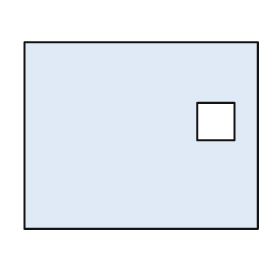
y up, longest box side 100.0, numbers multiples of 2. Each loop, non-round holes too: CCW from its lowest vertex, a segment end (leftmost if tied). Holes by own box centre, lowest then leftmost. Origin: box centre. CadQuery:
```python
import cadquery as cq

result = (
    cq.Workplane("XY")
    .moveTo(-50.0, -40.0)
    .lineTo(50.0, -40.0)
    .lineTo(50.0, 40.0)
    .lineTo(-50.0, 40.0)
    .close()
    .moveTo(24.0, -2.0)
    .lineTo(40.0, -2.0)
    .lineTo(40.0, 14.0)
    .lineTo(24.0, 14.0)
    .close()
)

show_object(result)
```